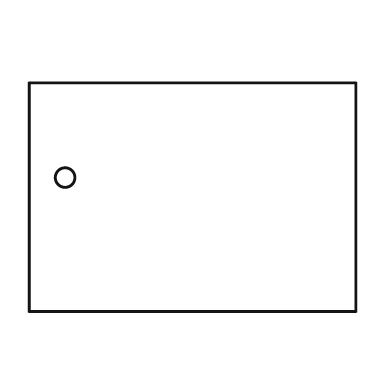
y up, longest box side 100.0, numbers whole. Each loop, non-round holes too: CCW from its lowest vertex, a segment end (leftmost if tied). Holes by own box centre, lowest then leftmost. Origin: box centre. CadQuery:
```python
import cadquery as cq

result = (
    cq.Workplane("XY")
    .moveTo(-50.0, -35.0)
    .lineTo(50.0, -35.0)
    .lineTo(50.0, 35.0)
    .lineTo(-50.0, 35.0)
    .close()
    .moveTo(-39.0, 6.0)
    .circle(3.0)
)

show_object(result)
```